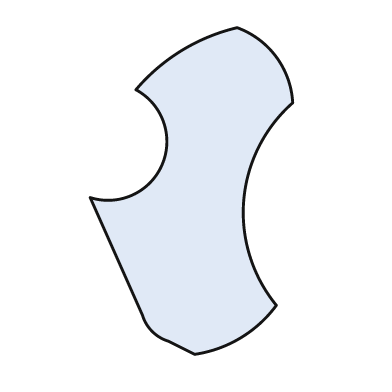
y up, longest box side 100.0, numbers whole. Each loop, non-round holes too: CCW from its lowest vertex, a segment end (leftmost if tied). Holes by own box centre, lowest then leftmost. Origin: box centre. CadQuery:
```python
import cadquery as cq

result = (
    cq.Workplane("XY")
    .moveTo(1.0, -50.0)
    .threePointArc((15.0, -45.0), (26.0, -35.0))
    .threePointArc((16.0, -3.0), (31.0, 27.0))
    .threePointArc((26.0, 41.0), (14.0, 50.0))
    .threePointArc((-3.0, 43.0), (-17.0, 31.0))
    .threePointArc((-9.0, 8.0), (-31.0, -2.0))
    .lineTo(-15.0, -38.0)
    .threePointArc((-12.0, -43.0), (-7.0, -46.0))
    .close()
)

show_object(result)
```